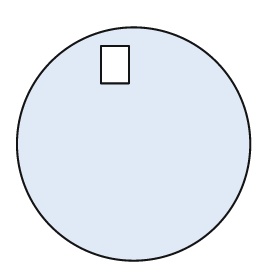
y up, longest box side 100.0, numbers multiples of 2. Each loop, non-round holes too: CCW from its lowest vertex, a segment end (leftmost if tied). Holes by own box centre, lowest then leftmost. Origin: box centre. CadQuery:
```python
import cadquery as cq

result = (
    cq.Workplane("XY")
    .moveTo(0.0, 0.0)
    .circle(50.0)
    .moveTo(-14.0, 26.0)
    .lineTo(-2.0, 26.0)
    .lineTo(-2.0, 42.0)
    .lineTo(-14.0, 42.0)
    .close()
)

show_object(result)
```